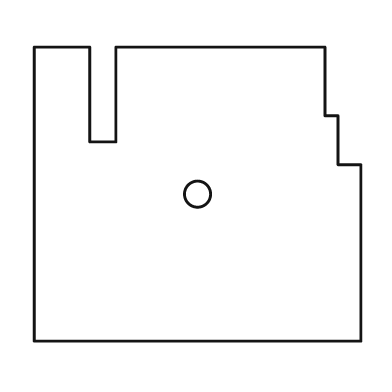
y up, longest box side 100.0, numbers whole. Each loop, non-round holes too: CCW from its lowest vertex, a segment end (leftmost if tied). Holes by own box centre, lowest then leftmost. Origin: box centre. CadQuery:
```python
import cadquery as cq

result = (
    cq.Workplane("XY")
    .moveTo(-50.0, -45.0)
    .lineTo(50.0, -45.0)
    .lineTo(50.0, 9.0)
    .lineTo(43.0, 9.0)
    .lineTo(43.0, 24.0)
    .lineTo(39.0, 24.0)
    .lineTo(39.0, 45.0)
    .lineTo(-25.0, 45.0)
    .lineTo(-25.0, 16.0)
    .lineTo(-33.0, 16.0)
    .lineTo(-33.0, 45.0)
    .lineTo(-50.0, 45.0)
    .close()
    .moveTo(0.0, 0.0)
    .circle(4.0)
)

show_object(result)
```